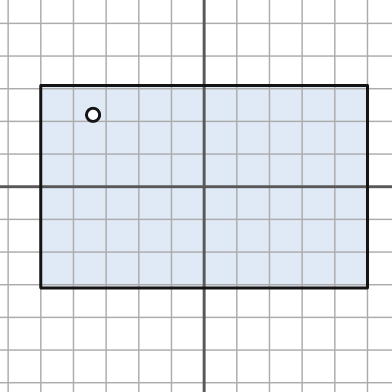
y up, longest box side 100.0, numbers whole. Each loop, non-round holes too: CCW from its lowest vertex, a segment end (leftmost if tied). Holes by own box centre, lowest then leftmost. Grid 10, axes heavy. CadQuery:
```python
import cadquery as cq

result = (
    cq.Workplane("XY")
    .moveTo(-50.0, -31.0)
    .lineTo(50.0, -31.0)
    .lineTo(50.0, 31.0)
    .lineTo(-50.0, 31.0)
    .close()
    .moveTo(-34.0, 22.0)
    .circle(2.0)
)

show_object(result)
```